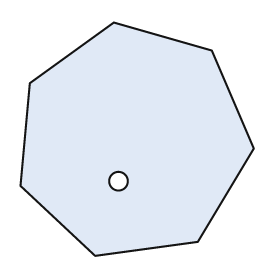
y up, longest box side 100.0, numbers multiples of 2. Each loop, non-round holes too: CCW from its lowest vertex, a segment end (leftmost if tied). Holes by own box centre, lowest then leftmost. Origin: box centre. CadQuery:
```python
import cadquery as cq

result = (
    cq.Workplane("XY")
    .moveTo(-18.0, -50.0)
    .lineTo(26.0, -44.0)
    .lineTo(50.0, -4.0)
    .lineTo(32.0, 38.0)
    .lineTo(-10.0, 50.0)
    .lineTo(-46.0, 24.0)
    .lineTo(-50.0, -20.0)
    .close()
    .moveTo(-8.0, -18.0)
    .circle(4.0)
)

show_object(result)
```